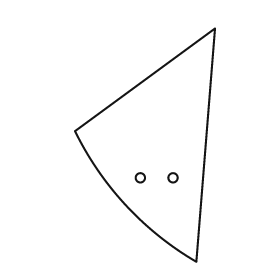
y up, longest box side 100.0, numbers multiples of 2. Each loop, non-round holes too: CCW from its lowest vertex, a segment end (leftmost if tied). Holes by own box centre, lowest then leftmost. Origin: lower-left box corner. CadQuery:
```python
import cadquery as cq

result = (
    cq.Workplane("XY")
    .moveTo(52.0, 0.0)
    .lineTo(60.0, 100.0)
    .lineTo(0.0, 56.0)
    .threePointArc((22.0, 24.0), (52.0, 0.0))
    .close()
    .moveTo(28.0, 36.0)
    .circle(2.0)
    .moveTo(42.0, 36.0)
    .circle(2.0)
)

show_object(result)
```